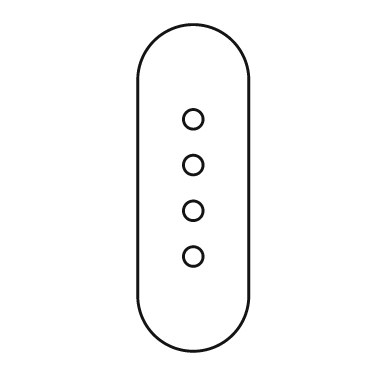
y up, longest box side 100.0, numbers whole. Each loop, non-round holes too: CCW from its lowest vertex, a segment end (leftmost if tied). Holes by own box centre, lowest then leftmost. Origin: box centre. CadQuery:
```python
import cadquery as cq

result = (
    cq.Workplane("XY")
    .moveTo(-17.0, -33.0)
    .threePointArc((0.0, -50.0), (17.0, -33.0))
    .lineTo(17.0, 33.0)
    .threePointArc((0.0, 50.0), (-17.0, 33.0))
    .close()
    .moveTo(0.0, -21.0)
    .circle(3.0)
    .moveTo(0.0, -7.0)
    .circle(3.0)
    .moveTo(0.0, 7.0)
    .circle(3.0)
    .moveTo(0.0, 21.0)
    .circle(3.0)
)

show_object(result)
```